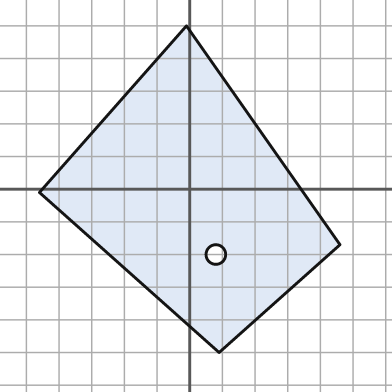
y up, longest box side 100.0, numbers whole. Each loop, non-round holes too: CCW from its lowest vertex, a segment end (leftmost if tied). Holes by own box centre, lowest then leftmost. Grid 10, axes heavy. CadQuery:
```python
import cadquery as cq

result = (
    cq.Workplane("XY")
    .moveTo(9.0, -50.0)
    .lineTo(46.0, -17.0)
    .lineTo(-1.0, 50.0)
    .lineTo(-46.0, -1.0)
    .close()
    .moveTo(8.0, -20.0)
    .circle(3.0)
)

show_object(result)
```